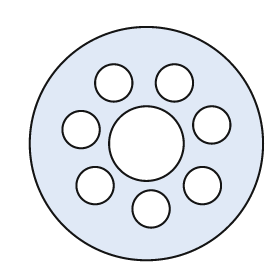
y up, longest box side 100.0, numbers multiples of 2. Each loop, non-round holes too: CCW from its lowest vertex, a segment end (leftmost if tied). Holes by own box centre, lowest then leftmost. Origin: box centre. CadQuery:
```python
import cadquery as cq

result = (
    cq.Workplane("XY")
    .moveTo(0.0, 0.0)
    .circle(50.0)
    .moveTo(2.0, -28.0)
    .circle(8.0)
    .moveTo(-22.0, -18.0)
    .circle(8.0)
    .moveTo(24.0, -18.0)
    .circle(8.0)
    .moveTo(0.0, 0.0)
    .circle(16.0)
    .moveTo(-28.0, 6.0)
    .circle(8.0)
    .moveTo(28.0, 8.0)
    .circle(8.0)
    .moveTo(-14.0, 26.0)
    .circle(8.0)
    .moveTo(12.0, 26.0)
    .circle(8.0)
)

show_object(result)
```